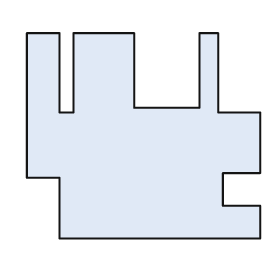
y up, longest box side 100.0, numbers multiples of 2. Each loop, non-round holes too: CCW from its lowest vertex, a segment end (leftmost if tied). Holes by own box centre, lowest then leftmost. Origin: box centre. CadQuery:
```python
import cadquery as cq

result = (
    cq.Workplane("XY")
    .moveTo(-36.0, -44.0)
    .lineTo(50.0, -44.0)
    .lineTo(50.0, -30.0)
    .lineTo(34.0, -30.0)
    .lineTo(34.0, -16.0)
    .lineTo(50.0, -16.0)
    .lineTo(50.0, 10.0)
    .lineTo(32.0, 10.0)
    .lineTo(32.0, 44.0)
    .lineTo(24.0, 44.0)
    .lineTo(24.0, 12.0)
    .lineTo(-4.0, 12.0)
    .lineTo(-4.0, 44.0)
    .lineTo(-30.0, 44.0)
    .lineTo(-30.0, 10.0)
    .lineTo(-36.0, 10.0)
    .lineTo(-36.0, 44.0)
    .lineTo(-50.0, 44.0)
    .lineTo(-50.0, -18.0)
    .lineTo(-36.0, -18.0)
    .close()
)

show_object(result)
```